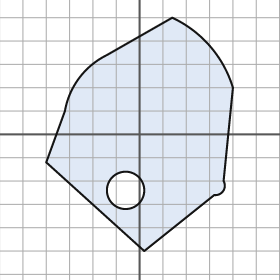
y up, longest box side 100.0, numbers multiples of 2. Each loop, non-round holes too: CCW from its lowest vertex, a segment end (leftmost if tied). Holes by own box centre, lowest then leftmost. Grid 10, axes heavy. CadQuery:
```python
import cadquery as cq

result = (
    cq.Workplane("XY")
    .moveTo(2.0, -50.0)
    .lineTo(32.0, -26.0)
    .threePointArc((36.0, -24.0), (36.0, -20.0))
    .lineTo(40.0, 20.0)
    .threePointArc((30.0, 38.0), (14.0, 50.0))
    .lineTo(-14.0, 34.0)
    .threePointArc((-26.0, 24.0), (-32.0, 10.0))
    .lineTo(-40.0, -12.0)
    .close()
    .moveTo(-6.0, -24.0)
    .circle(8.0)
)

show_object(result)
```